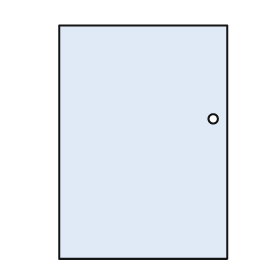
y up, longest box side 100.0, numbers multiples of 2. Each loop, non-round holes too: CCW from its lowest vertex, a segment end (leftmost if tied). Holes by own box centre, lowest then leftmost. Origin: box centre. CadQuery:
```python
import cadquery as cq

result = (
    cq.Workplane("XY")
    .moveTo(-36.0, -50.0)
    .lineTo(36.0, -50.0)
    .lineTo(36.0, 50.0)
    .lineTo(-36.0, 50.0)
    .close()
    .moveTo(30.0, 10.0)
    .circle(2.0)
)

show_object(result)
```